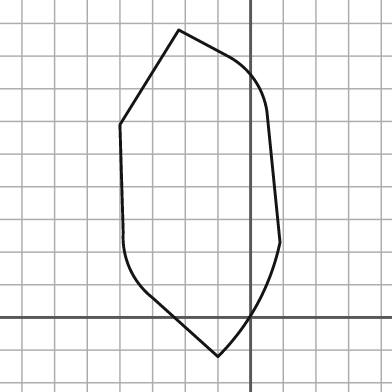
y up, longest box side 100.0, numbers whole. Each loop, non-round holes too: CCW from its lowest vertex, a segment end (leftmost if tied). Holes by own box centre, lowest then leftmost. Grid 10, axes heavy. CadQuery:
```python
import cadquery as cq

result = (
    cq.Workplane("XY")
    .moveTo(-10.0, -12.0)
    .threePointArc((2.0, 4.0), (9.0, 23.0))
    .lineTo(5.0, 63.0)
    .threePointArc((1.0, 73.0), (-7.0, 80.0))
    .lineTo(-22.0, 88.0)
    .lineTo(-40.0, 59.0)
    .lineTo(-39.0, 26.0)
    .threePointArc((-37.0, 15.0), (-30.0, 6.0))
    .close()
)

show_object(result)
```